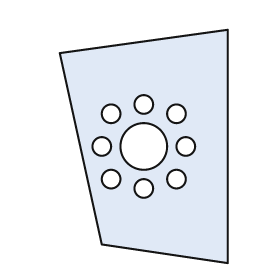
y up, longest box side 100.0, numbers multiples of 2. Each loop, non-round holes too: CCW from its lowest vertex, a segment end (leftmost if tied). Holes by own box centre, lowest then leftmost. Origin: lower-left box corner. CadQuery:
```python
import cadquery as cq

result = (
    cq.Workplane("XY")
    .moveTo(72.0, 0.0)
    .lineTo(72.0, 100.0)
    .lineTo(0.0, 90.0)
    .lineTo(18.0, 8.0)
    .close()
    .moveTo(36.0, 32.0)
    .circle(4.0)
    .moveTo(22.0, 36.0)
    .circle(4.0)
    .moveTo(50.0, 36.0)
    .circle(4.0)
    .moveTo(18.0, 50.0)
    .circle(4.0)
    .moveTo(36.0, 50.0)
    .circle(10.0)
    .moveTo(54.0, 50.0)
    .circle(4.0)
    .moveTo(22.0, 64.0)
    .circle(4.0)
    .moveTo(50.0, 64.0)
    .circle(4.0)
    .moveTo(36.0, 68.0)
    .circle(4.0)
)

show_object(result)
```